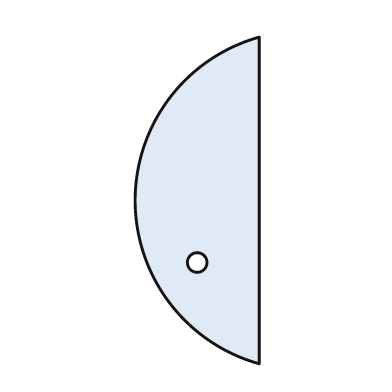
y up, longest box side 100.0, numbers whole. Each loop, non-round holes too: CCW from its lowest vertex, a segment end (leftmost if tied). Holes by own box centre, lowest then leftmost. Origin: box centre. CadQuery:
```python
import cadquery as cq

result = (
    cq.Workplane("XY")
    .moveTo(19.0, -50.0)
    .lineTo(19.0, 50.0)
    .threePointArc((-19.0, 0.0), (19.0, -50.0))
    .close()
    .moveTo(0.0, -19.0)
    .circle(3.0)
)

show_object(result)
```